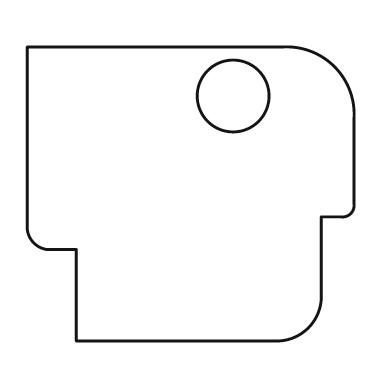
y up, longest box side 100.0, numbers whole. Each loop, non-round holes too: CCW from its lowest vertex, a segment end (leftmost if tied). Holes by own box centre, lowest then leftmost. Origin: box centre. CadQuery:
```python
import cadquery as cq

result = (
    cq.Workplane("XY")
    .moveTo(-35.0, -45.0)
    .lineTo(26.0, -45.0)
    .threePointArc((36.0, -41.0), (40.0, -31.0))
    .lineTo(40.0, -7.0)
    .lineTo(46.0, -7.0)
    .threePointArc((49.0, -6.0), (50.0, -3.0))
    .lineTo(50.0, 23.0)
    .threePointArc((44.0, 39.0), (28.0, 45.0))
    .lineTo(-50.0, 45.0)
    .lineTo(-50.0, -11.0)
    .threePointArc((-48.0, -15.0), (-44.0, -17.0))
    .lineTo(-35.0, -17.0)
    .close()
    .moveTo(13.0, 30.0)
    .circle(11.0)
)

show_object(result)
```